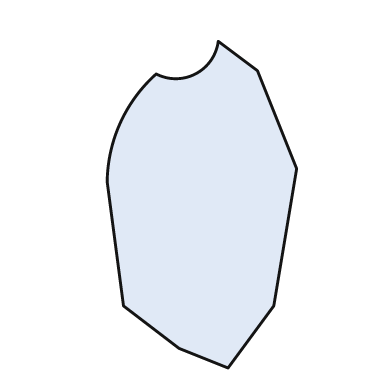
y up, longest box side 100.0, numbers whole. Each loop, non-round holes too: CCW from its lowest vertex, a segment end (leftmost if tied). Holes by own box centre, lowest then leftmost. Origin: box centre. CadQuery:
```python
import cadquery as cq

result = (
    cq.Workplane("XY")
    .moveTo(8.0, -50.0)
    .lineTo(22.0, -31.0)
    .lineTo(29.0, 11.0)
    .lineTo(17.0, 41.0)
    .lineTo(5.0, 50.0)
    .threePointArc((-2.0, 40.0), (-14.0, 40.0))
    .threePointArc((-25.0, 25.0), (-29.0, 7.0))
    .lineTo(-24.0, -31.0)
    .lineTo(-7.0, -44.0)
    .close()
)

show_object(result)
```